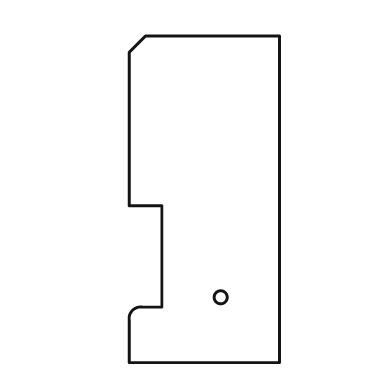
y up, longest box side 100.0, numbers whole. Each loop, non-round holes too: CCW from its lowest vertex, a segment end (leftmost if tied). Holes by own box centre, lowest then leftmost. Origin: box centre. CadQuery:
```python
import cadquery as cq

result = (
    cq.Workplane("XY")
    .moveTo(-23.0, -50.0)
    .lineTo(23.0, -50.0)
    .lineTo(23.0, 50.0)
    .lineTo(-18.0, 50.0)
    .lineTo(-23.0, 45.0)
    .lineTo(-23.0, -2.0)
    .lineTo(-13.0, -2.0)
    .lineTo(-13.0, -33.0)
    .lineTo(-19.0, -33.0)
    .threePointArc((-22.0, -34.0), (-23.0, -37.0))
    .close()
    .moveTo(5.0, -30.0)
    .circle(2.0)
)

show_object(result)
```